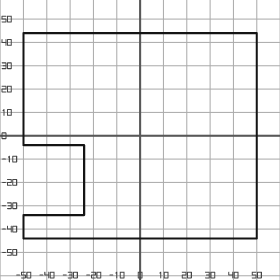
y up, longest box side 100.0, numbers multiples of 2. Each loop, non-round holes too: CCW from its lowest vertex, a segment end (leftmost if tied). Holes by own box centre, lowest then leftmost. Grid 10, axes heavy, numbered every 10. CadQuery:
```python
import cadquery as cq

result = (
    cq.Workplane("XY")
    .moveTo(-50.0, -44.0)
    .lineTo(50.0, -44.0)
    .lineTo(50.0, 44.0)
    .lineTo(-50.0, 44.0)
    .lineTo(-50.0, -4.0)
    .lineTo(-24.0, -4.0)
    .lineTo(-24.0, -34.0)
    .lineTo(-50.0, -34.0)
    .close()
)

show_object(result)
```